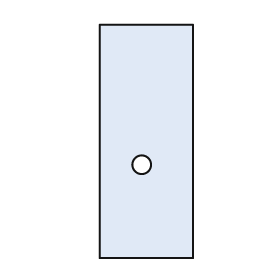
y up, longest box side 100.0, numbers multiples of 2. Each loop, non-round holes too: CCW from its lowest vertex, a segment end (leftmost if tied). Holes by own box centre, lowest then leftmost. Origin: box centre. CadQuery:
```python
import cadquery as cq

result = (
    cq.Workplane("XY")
    .moveTo(-20.0, -50.0)
    .lineTo(20.0, -50.0)
    .lineTo(20.0, 50.0)
    .lineTo(-20.0, 50.0)
    .close()
    .moveTo(-2.0, -10.0)
    .circle(4.0)
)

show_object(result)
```